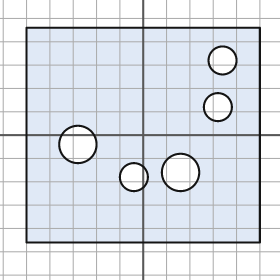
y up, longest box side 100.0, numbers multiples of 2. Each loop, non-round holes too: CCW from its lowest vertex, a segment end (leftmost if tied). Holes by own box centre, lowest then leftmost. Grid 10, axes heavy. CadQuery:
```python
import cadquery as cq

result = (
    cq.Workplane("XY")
    .moveTo(-50.0, -46.0)
    .lineTo(50.0, -46.0)
    .lineTo(50.0, 46.0)
    .lineTo(-50.0, 46.0)
    .close()
    .moveTo(-4.0, -18.0)
    .circle(6.0)
    .moveTo(16.0, -16.0)
    .circle(8.0)
    .moveTo(-28.0, -4.0)
    .circle(8.0)
    .moveTo(32.0, 12.0)
    .circle(6.0)
    .moveTo(34.0, 32.0)
    .circle(6.0)
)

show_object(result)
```